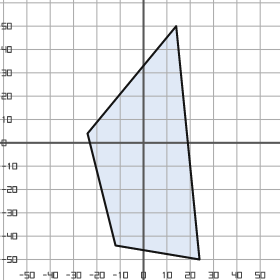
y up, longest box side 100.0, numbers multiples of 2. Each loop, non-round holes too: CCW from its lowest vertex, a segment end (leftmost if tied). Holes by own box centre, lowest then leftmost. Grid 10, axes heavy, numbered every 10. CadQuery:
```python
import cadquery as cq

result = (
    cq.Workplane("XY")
    .moveTo(24.0, -50.0)
    .lineTo(14.0, 50.0)
    .lineTo(-24.0, 4.0)
    .lineTo(-12.0, -44.0)
    .close()
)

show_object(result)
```